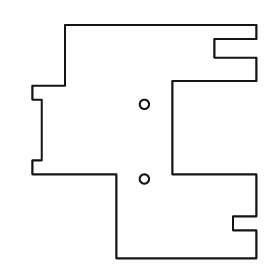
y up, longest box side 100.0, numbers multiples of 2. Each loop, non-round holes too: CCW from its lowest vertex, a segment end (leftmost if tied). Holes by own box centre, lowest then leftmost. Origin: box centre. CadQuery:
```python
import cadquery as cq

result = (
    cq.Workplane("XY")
    .moveTo(-12.0, -50.0)
    .lineTo(48.0, -50.0)
    .lineTo(48.0, -38.0)
    .lineTo(38.0, -38.0)
    .lineTo(38.0, -32.0)
    .lineTo(48.0, -32.0)
    .lineTo(48.0, -14.0)
    .lineTo(12.0, -14.0)
    .lineTo(12.0, 26.0)
    .lineTo(48.0, 26.0)
    .lineTo(48.0, 36.0)
    .lineTo(30.0, 36.0)
    .lineTo(30.0, 44.0)
    .lineTo(48.0, 44.0)
    .lineTo(48.0, 50.0)
    .lineTo(-34.0, 50.0)
    .lineTo(-34.0, 24.0)
    .lineTo(-48.0, 24.0)
    .lineTo(-48.0, 18.0)
    .lineTo(-44.0, 18.0)
    .lineTo(-44.0, -8.0)
    .lineTo(-48.0, -8.0)
    .lineTo(-48.0, -14.0)
    .lineTo(-12.0, -14.0)
    .close()
    .moveTo(0.0, -16.0)
    .circle(2.0)
    .moveTo(0.0, 16.0)
    .circle(2.0)
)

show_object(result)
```